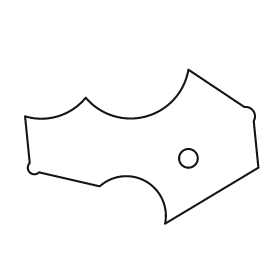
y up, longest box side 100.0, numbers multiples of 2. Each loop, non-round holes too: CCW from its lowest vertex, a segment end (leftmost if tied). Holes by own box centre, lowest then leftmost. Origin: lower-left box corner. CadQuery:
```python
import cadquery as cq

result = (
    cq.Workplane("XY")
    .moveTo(60.0, 0.0)
    .lineTo(100.0, 24.0)
    .lineTo(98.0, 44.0)
    .threePointArc((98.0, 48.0), (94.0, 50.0))
    .lineTo(70.0, 66.0)
    .threePointArc((52.0, 46.0), (26.0, 54.0))
    .threePointArc((14.0, 46.0), (0.0, 46.0))
    .lineTo(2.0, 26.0)
    .threePointArc((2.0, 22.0), (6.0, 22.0))
    .lineTo(32.0, 16.0)
    .threePointArc((52.0, 18.0), (60.0, 0.0))
    .close()
    .moveTo(70.0, 28.0)
    .circle(4.0)
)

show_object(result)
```